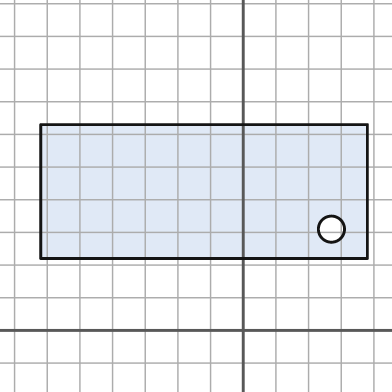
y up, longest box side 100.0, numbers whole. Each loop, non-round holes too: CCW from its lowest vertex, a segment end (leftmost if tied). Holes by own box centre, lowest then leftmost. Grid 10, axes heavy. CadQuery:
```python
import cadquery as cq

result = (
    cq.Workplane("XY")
    .moveTo(-62.0, 22.0)
    .lineTo(38.0, 22.0)
    .lineTo(38.0, 63.0)
    .lineTo(-62.0, 63.0)
    .close()
    .moveTo(27.0, 31.0)
    .circle(4.0)
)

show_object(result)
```